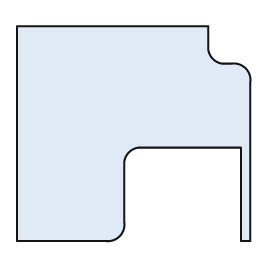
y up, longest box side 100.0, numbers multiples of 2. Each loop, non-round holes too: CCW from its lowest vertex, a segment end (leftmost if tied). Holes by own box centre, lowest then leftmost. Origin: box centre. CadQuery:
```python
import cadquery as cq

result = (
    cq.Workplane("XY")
    .moveTo(-50.0, -46.0)
    .lineTo(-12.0, -46.0)
    .threePointArc((-6.0, -44.0), (-4.0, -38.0))
    .lineTo(-4.0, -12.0)
    .threePointArc((-2.0, -8.0), (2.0, -6.0))
    .lineTo(46.0, -6.0)
    .lineTo(46.0, -46.0)
    .lineTo(50.0, -46.0)
    .lineTo(50.0, 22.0)
    .threePointArc((48.0, 28.0), (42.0, 30.0))
    .lineTo(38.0, 30.0)
    .threePointArc((34.0, 32.0), (32.0, 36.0))
    .lineTo(32.0, 46.0)
    .lineTo(-50.0, 46.0)
    .close()
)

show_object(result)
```